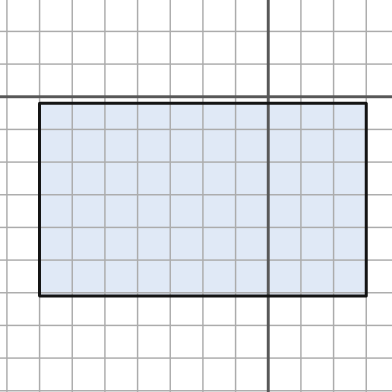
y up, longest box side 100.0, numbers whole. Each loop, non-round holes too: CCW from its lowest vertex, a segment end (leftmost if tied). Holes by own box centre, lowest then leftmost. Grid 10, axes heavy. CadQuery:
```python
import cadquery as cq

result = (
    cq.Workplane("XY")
    .moveTo(-70.0, -61.0)
    .lineTo(30.0, -61.0)
    .lineTo(30.0, -2.0)
    .lineTo(-70.0, -2.0)
    .close()
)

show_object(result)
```